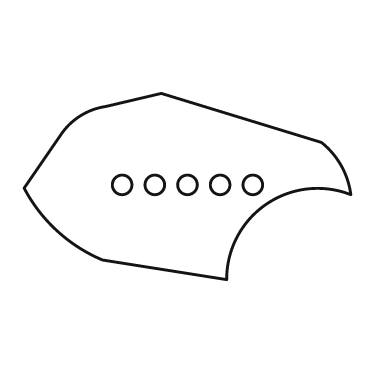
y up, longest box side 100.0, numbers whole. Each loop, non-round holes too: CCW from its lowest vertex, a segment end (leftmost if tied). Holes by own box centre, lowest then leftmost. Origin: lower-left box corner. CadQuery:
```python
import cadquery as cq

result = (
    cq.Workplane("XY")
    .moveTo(62.0, 0.0)
    .threePointArc((74.0, 23.0), (100.0, 26.0))
    .threePointArc((97.0, 35.0), (91.0, 42.0))
    .lineTo(42.0, 57.0)
    .lineTo(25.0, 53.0)
    .threePointArc((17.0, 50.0), (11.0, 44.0))
    .lineTo(0.0, 28.0)
    .threePointArc((10.0, 15.0), (24.0, 6.0))
    .close()
    .moveTo(30.0, 29.0)
    .circle(3.0)
    .moveTo(40.0, 29.0)
    .circle(3.0)
    .moveTo(50.0, 29.0)
    .circle(3.0)
    .moveTo(60.0, 29.0)
    .circle(3.0)
    .moveTo(70.0, 29.0)
    .circle(3.0)
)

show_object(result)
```